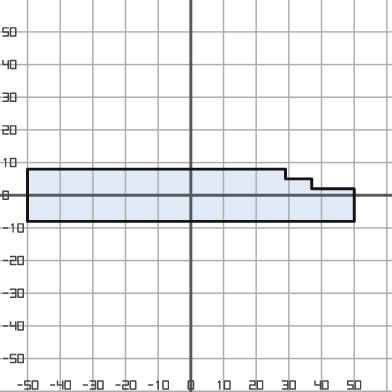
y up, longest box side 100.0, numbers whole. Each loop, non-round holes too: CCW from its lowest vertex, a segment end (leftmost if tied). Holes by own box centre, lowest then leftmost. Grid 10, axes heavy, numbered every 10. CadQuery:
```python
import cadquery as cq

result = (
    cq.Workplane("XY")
    .moveTo(-50.0, -8.0)
    .lineTo(50.0, -8.0)
    .lineTo(50.0, 2.0)
    .lineTo(37.0, 2.0)
    .lineTo(37.0, 5.0)
    .lineTo(29.0, 5.0)
    .lineTo(29.0, 8.0)
    .lineTo(-50.0, 8.0)
    .close()
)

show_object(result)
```